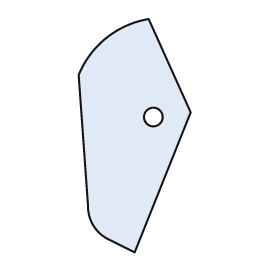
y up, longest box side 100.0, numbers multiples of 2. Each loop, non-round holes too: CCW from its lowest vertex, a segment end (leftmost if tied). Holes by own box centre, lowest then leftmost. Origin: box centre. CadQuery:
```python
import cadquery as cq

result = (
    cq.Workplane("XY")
    .moveTo(0.0, -50.0)
    .lineTo(24.0, 10.0)
    .lineTo(6.0, 50.0)
    .threePointArc((-12.0, 42.0), (-24.0, 26.0))
    .lineTo(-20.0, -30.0)
    .threePointArc((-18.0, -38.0), (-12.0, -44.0))
    .close()
    .moveTo(8.0, 8.0)
    .circle(4.0)
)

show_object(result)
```